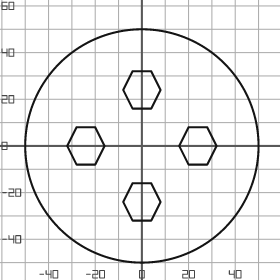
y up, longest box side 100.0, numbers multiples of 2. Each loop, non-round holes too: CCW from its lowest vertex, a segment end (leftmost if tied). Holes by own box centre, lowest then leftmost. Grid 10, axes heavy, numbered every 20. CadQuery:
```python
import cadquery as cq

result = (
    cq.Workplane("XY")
    .moveTo(0.0, 0.0)
    .circle(50.0)
    .moveTo(-4.0, -32.0)
    .lineTo(4.0, -32.0)
    .lineTo(8.0, -24.0)
    .lineTo(4.0, -16.0)
    .lineTo(-4.0, -16.0)
    .lineTo(-8.0, -24.0)
    .close()
    .moveTo(-28.0, -8.0)
    .lineTo(-20.0, -8.0)
    .lineTo(-16.0, 0.0)
    .lineTo(-20.0, 8.0)
    .lineTo(-28.0, 8.0)
    .lineTo(-32.0, 0.0)
    .close()
    .moveTo(20.0, -8.0)
    .lineTo(28.0, -8.0)
    .lineTo(32.0, 0.0)
    .lineTo(28.0, 8.0)
    .lineTo(20.0, 8.0)
    .lineTo(16.0, 0.0)
    .close()
    .moveTo(-4.0, 16.0)
    .lineTo(4.0, 16.0)
    .lineTo(8.0, 24.0)
    .lineTo(4.0, 32.0)
    .lineTo(-4.0, 32.0)
    .lineTo(-8.0, 24.0)
    .close()
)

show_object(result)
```